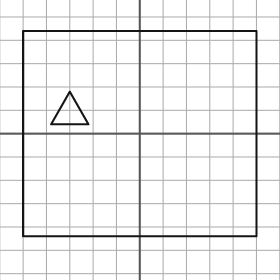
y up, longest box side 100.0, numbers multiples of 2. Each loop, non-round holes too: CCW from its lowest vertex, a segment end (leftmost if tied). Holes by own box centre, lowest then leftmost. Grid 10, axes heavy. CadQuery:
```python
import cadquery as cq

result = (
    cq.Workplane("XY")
    .moveTo(-50.0, -44.0)
    .lineTo(50.0, -44.0)
    .lineTo(50.0, 44.0)
    .lineTo(-50.0, 44.0)
    .close()
    .moveTo(-38.0, 4.0)
    .lineTo(-22.0, 4.0)
    .lineTo(-30.0, 18.0)
    .close()
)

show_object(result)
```